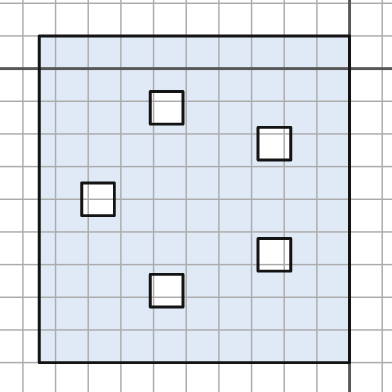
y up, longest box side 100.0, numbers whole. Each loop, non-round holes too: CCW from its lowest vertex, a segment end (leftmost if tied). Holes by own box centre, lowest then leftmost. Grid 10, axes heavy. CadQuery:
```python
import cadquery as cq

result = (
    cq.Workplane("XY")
    .moveTo(-95.0, -90.0)
    .lineTo(0.0, -90.0)
    .lineTo(0.0, 10.0)
    .lineTo(-95.0, 10.0)
    .close()
    .moveTo(-61.0, -73.0)
    .lineTo(-51.0, -73.0)
    .lineTo(-51.0, -63.0)
    .lineTo(-61.0, -63.0)
    .close()
    .moveTo(-28.0, -62.0)
    .lineTo(-18.0, -62.0)
    .lineTo(-18.0, -52.0)
    .lineTo(-28.0, -52.0)
    .close()
    .moveTo(-82.0, -45.0)
    .lineTo(-72.0, -45.0)
    .lineTo(-72.0, -35.0)
    .lineTo(-82.0, -35.0)
    .close()
    .moveTo(-28.0, -28.0)
    .lineTo(-18.0, -28.0)
    .lineTo(-18.0, -18.0)
    .lineTo(-28.0, -18.0)
    .close()
    .moveTo(-61.0, -17.0)
    .lineTo(-51.0, -17.0)
    .lineTo(-51.0, -7.0)
    .lineTo(-61.0, -7.0)
    .close()
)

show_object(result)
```